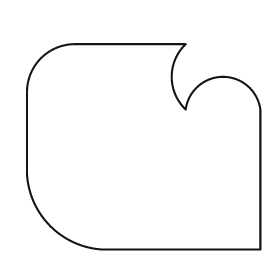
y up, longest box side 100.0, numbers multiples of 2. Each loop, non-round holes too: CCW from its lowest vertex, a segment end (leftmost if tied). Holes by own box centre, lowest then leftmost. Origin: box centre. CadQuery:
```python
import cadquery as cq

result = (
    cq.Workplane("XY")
    .moveTo(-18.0, -44.0)
    .lineTo(50.0, -44.0)
    .lineTo(50.0, 16.0)
    .threePointArc((34.0, 30.0), (18.0, 16.0))
    .threePointArc((12.0, 30.0), (18.0, 44.0))
    .lineTo(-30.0, 44.0)
    .threePointArc((-44.0, 38.0), (-50.0, 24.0))
    .lineTo(-50.0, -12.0)
    .threePointArc((-40.0, -34.0), (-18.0, -44.0))
    .close()
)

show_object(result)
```